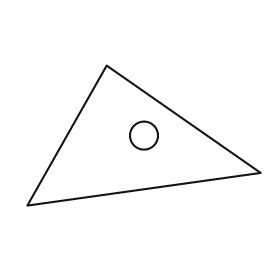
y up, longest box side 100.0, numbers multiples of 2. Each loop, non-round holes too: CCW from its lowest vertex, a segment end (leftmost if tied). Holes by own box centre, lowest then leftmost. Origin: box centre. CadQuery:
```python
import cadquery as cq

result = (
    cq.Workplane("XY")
    .moveTo(-50.0, -30.0)
    .lineTo(50.0, -16.0)
    .lineTo(-16.0, 30.0)
    .close()
    .moveTo(0.0, 0.0)
    .circle(6.0)
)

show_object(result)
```